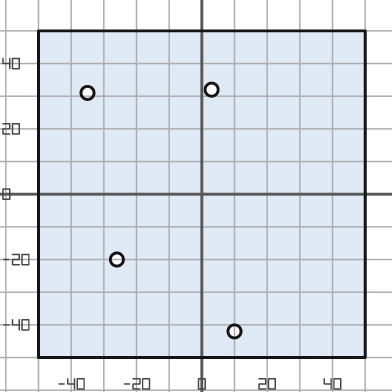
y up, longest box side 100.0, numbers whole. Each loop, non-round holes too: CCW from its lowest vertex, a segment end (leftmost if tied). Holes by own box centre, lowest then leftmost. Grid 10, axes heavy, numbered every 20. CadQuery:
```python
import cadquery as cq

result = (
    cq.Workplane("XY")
    .moveTo(-50.0, -50.0)
    .lineTo(50.0, -50.0)
    .lineTo(50.0, 50.0)
    .lineTo(-50.0, 50.0)
    .close()
    .moveTo(10.0, -42.0)
    .circle(2.0)
    .moveTo(-26.0, -20.0)
    .circle(2.0)
    .moveTo(-35.0, 31.0)
    .circle(2.0)
    .moveTo(3.0, 32.0)
    .circle(2.0)
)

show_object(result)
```